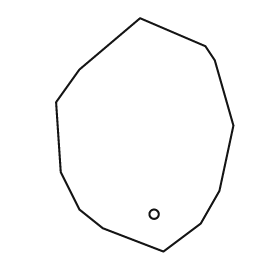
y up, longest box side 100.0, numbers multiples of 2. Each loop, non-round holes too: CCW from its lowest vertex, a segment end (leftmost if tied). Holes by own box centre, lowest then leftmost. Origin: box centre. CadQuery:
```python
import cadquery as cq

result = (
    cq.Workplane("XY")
    .moveTo(8.0, -50.0)
    .lineTo(24.0, -38.0)
    .lineTo(32.0, -24.0)
    .lineTo(38.0, 4.0)
    .lineTo(30.0, 32.0)
    .lineTo(26.0, 38.0)
    .lineTo(-2.0, 50.0)
    .lineTo(-28.0, 28.0)
    .lineTo(-38.0, 14.0)
    .lineTo(-36.0, -16.0)
    .lineTo(-28.0, -32.0)
    .lineTo(-18.0, -40.0)
    .close()
    .moveTo(4.0, -34.0)
    .circle(2.0)
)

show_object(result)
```